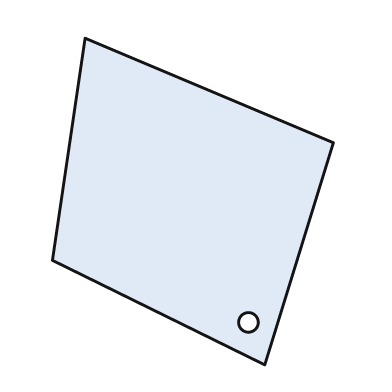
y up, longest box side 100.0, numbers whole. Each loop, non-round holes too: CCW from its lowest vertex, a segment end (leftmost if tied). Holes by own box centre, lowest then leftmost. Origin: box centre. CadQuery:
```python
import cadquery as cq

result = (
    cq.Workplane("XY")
    .moveTo(22.0, -50.0)
    .lineTo(43.0, 18.0)
    .lineTo(-33.0, 50.0)
    .lineTo(-43.0, -18.0)
    .close()
    .moveTo(17.0, -37.0)
    .circle(3.0)
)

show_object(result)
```